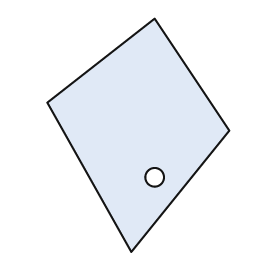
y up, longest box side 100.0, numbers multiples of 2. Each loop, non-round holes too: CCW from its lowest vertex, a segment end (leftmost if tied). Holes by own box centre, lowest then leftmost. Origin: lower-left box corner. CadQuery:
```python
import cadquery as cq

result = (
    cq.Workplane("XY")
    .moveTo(36.0, 0.0)
    .lineTo(78.0, 52.0)
    .lineTo(46.0, 100.0)
    .lineTo(0.0, 64.0)
    .close()
    .moveTo(46.0, 32.0)
    .circle(4.0)
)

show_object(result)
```